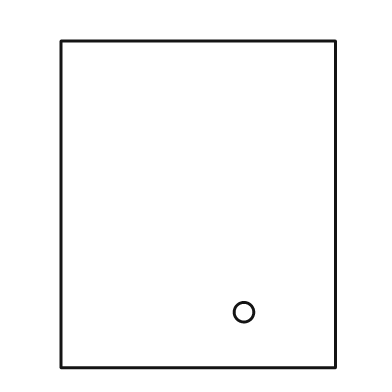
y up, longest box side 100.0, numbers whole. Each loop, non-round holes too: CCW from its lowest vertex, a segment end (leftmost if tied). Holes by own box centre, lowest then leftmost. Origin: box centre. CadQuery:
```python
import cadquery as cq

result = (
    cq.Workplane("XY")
    .moveTo(-42.0, -50.0)
    .lineTo(42.0, -50.0)
    .lineTo(42.0, 50.0)
    .lineTo(-42.0, 50.0)
    .close()
    .moveTo(14.0, -33.0)
    .circle(3.0)
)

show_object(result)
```